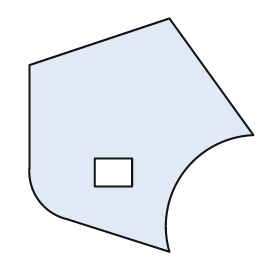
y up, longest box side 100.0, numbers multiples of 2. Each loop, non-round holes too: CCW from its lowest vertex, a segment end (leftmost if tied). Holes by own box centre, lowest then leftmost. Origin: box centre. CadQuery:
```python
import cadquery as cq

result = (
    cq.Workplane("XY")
    .moveTo(12.0, -50.0)
    .threePointArc((18.0, -16.0), (48.0, 0.0))
    .lineTo(12.0, 50.0)
    .lineTo(-48.0, 30.0)
    .lineTo(-48.0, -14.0)
    .threePointArc((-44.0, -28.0), (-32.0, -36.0))
    .close()
    .moveTo(-20.0, -22.0)
    .lineTo(-4.0, -22.0)
    .lineTo(-4.0, -10.0)
    .lineTo(-20.0, -10.0)
    .close()
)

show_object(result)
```